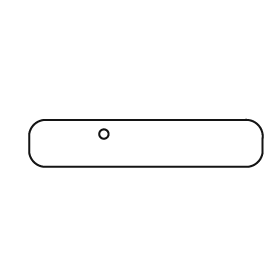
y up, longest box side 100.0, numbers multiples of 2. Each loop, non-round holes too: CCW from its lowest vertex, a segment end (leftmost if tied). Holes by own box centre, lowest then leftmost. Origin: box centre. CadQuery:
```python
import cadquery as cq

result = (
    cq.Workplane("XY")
    .moveTo(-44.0, -10.0)
    .lineTo(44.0, -10.0)
    .threePointArc((48.0, -8.0), (50.0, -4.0))
    .lineTo(50.0, 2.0)
    .threePointArc((48.0, 8.0), (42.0, 10.0))
    .lineTo(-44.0, 10.0)
    .threePointArc((-48.0, 8.0), (-50.0, 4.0))
    .lineTo(-50.0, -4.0)
    .threePointArc((-48.0, -8.0), (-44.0, -10.0))
    .close()
    .moveTo(-18.0, 4.0)
    .circle(2.0)
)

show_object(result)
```